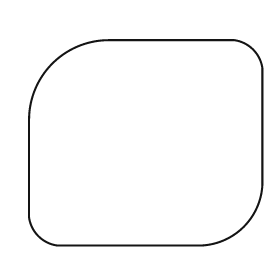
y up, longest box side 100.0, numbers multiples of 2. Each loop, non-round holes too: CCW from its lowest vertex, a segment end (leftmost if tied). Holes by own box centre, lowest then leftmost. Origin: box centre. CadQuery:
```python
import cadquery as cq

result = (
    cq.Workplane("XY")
    .moveTo(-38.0, -44.0)
    .lineTo(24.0, -44.0)
    .threePointArc((42.0, -36.0), (50.0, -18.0))
    .lineTo(50.0, 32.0)
    .threePointArc((46.0, 40.0), (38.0, 44.0))
    .lineTo(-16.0, 44.0)
    .threePointArc((-40.0, 34.0), (-50.0, 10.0))
    .lineTo(-50.0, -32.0)
    .threePointArc((-46.0, -40.0), (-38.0, -44.0))
    .close()
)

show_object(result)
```